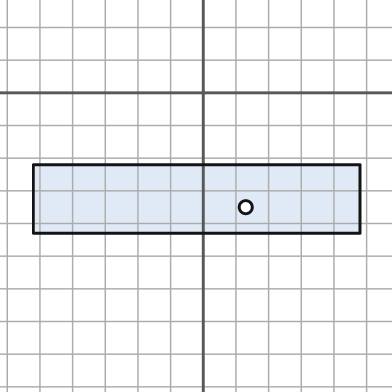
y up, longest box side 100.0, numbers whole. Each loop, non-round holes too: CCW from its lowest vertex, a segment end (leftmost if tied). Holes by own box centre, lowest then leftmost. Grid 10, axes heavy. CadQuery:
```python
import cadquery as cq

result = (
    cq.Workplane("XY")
    .moveTo(-52.0, -43.0)
    .lineTo(48.0, -43.0)
    .lineTo(48.0, -22.0)
    .lineTo(-52.0, -22.0)
    .close()
    .moveTo(13.0, -35.0)
    .circle(2.0)
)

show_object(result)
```